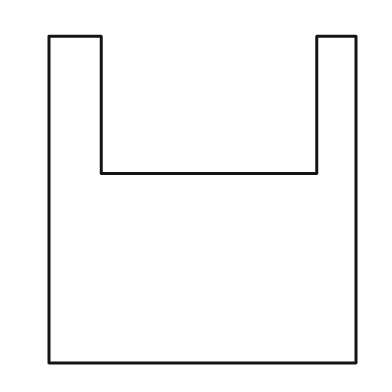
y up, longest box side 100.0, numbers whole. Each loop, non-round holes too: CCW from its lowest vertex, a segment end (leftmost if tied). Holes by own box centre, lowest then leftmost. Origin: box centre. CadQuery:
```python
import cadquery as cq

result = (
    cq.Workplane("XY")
    .moveTo(-47.0, -50.0)
    .lineTo(47.0, -50.0)
    .lineTo(47.0, 50.0)
    .lineTo(35.0, 50.0)
    .lineTo(35.0, 8.0)
    .lineTo(-31.0, 8.0)
    .lineTo(-31.0, 50.0)
    .lineTo(-47.0, 50.0)
    .close()
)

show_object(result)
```